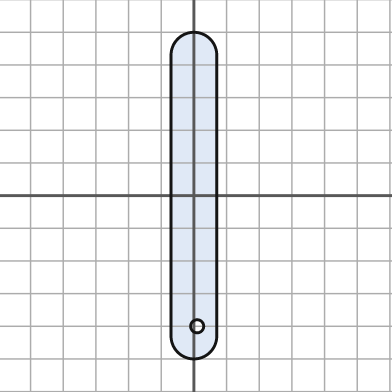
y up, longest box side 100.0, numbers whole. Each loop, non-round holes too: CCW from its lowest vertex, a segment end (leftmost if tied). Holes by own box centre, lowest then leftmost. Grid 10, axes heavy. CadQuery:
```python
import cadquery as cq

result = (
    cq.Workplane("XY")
    .moveTo(-7.0, -43.0)
    .threePointArc((0.0, -50.0), (7.0, -43.0))
    .lineTo(7.0, 43.0)
    .threePointArc((0.0, 50.0), (-7.0, 43.0))
    .close()
    .moveTo(1.0, -40.0)
    .circle(2.0)
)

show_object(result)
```